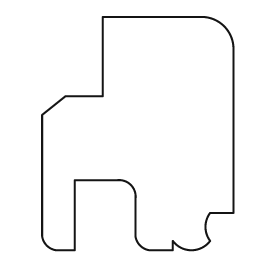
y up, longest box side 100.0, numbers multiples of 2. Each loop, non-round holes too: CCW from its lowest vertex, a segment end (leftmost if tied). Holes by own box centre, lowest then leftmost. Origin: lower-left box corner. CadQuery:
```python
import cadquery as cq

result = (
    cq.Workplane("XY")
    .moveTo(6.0, 0.0)
    .lineTo(14.0, 0.0)
    .lineTo(14.0, 30.0)
    .lineTo(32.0, 30.0)
    .threePointArc((38.0, 28.0), (40.0, 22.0))
    .lineTo(40.0, 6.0)
    .threePointArc((42.0, 2.0), (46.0, 0.0))
    .lineTo(56.0, 0.0)
    .lineTo(56.0, 4.0)
    .threePointArc((64.0, 0.0), (72.0, 4.0))
    .threePointArc((70.0, 10.0), (72.0, 16.0))
    .lineTo(82.0, 16.0)
    .lineTo(82.0, 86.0)
    .threePointArc((78.0, 96.0), (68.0, 100.0))
    .lineTo(26.0, 100.0)
    .lineTo(26.0, 66.0)
    .lineTo(10.0, 66.0)
    .lineTo(0.0, 58.0)
    .lineTo(0.0, 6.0)
    .threePointArc((2.0, 2.0), (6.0, 0.0))
    .close()
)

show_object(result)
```